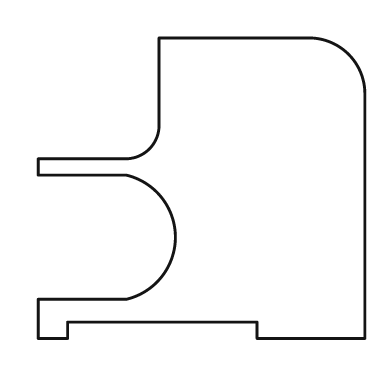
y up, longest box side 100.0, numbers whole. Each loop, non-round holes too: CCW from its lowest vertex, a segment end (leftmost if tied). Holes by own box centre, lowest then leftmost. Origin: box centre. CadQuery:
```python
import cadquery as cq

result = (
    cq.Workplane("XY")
    .moveTo(-50.0, -46.0)
    .lineTo(-41.0, -46.0)
    .lineTo(-41.0, -41.0)
    .lineTo(17.0, -41.0)
    .lineTo(17.0, -46.0)
    .lineTo(50.0, -46.0)
    .lineTo(50.0, 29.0)
    .threePointArc((45.0, 41.0), (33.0, 46.0))
    .lineTo(-13.0, 46.0)
    .lineTo(-13.0, 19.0)
    .threePointArc((-16.0, 12.0), (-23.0, 9.0))
    .lineTo(-50.0, 9.0)
    .lineTo(-50.0, 4.0)
    .lineTo(-23.0, 4.0)
    .threePointArc((-8.0, -15.0), (-23.0, -34.0))
    .lineTo(-50.0, -34.0)
    .close()
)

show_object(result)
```